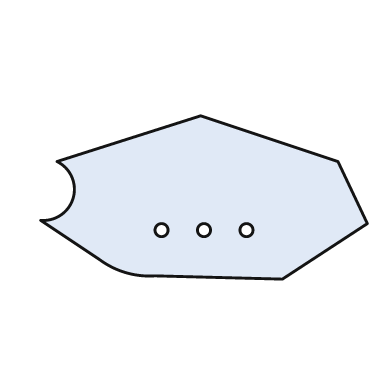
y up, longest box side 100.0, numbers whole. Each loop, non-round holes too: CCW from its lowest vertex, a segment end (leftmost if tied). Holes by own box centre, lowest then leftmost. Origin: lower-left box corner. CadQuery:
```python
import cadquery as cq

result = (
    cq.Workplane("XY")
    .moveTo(74.0, 0.0)
    .lineTo(100.0, 17.0)
    .lineTo(91.0, 36.0)
    .lineTo(49.0, 50.0)
    .lineTo(5.0, 36.0)
    .threePointArc((10.0, 25.0), (0.0, 18.0))
    .lineTo(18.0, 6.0)
    .threePointArc((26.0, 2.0), (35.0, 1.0))
    .close()
    .moveTo(37.0, 15.0)
    .circle(2.0)
    .moveTo(50.0, 15.0)
    .circle(2.0)
    .moveTo(63.0, 15.0)
    .circle(2.0)
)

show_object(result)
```